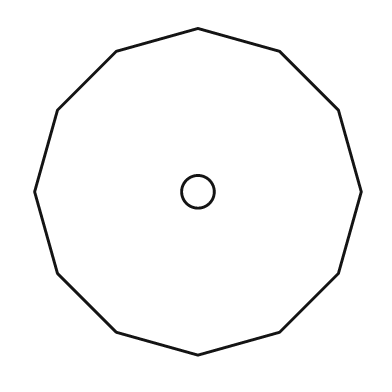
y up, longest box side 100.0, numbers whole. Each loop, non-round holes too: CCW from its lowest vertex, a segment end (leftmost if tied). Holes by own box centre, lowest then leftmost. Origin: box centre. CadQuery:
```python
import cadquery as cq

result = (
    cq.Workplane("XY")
    .moveTo(0.0, -50.0)
    .lineTo(25.0, -43.0)
    .lineTo(43.0, -25.0)
    .lineTo(50.0, 0.0)
    .lineTo(43.0, 25.0)
    .lineTo(25.0, 43.0)
    .lineTo(0.0, 50.0)
    .lineTo(-25.0, 43.0)
    .lineTo(-43.0, 25.0)
    .lineTo(-50.0, 0.0)
    .lineTo(-43.0, -25.0)
    .lineTo(-25.0, -43.0)
    .close()
    .moveTo(0.0, 0.0)
    .circle(5.0)
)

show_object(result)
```